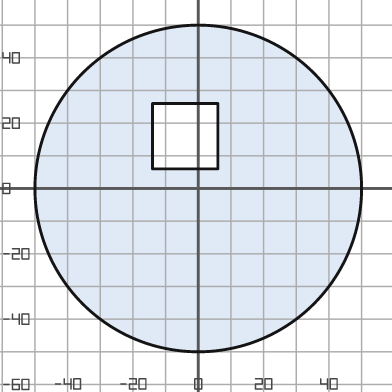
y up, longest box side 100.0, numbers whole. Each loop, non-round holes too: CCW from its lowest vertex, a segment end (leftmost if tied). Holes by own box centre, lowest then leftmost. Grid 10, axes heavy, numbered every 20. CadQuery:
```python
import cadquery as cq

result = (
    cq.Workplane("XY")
    .moveTo(0.0, 0.0)
    .circle(50.0)
    .moveTo(-14.0, 6.0)
    .lineTo(6.0, 6.0)
    .lineTo(6.0, 26.0)
    .lineTo(-14.0, 26.0)
    .close()
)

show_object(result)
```